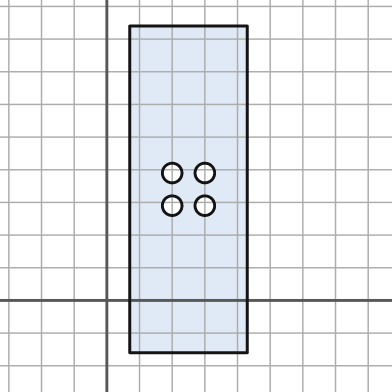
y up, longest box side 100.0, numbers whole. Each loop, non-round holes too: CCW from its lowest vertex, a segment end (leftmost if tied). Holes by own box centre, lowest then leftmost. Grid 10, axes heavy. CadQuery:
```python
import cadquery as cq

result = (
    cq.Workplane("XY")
    .moveTo(7.0, -16.0)
    .lineTo(43.0, -16.0)
    .lineTo(43.0, 84.0)
    .lineTo(7.0, 84.0)
    .close()
    .moveTo(20.0, 29.0)
    .circle(3.0)
    .moveTo(30.0, 29.0)
    .circle(3.0)
    .moveTo(20.0, 39.0)
    .circle(3.0)
    .moveTo(30.0, 39.0)
    .circle(3.0)
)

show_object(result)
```